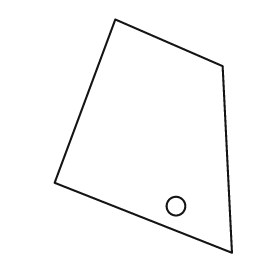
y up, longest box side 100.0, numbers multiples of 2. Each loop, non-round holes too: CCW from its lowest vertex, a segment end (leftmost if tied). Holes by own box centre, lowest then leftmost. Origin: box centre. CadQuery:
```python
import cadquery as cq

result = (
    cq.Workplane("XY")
    .moveTo(38.0, -50.0)
    .lineTo(34.0, 30.0)
    .lineTo(-12.0, 50.0)
    .lineTo(-38.0, -20.0)
    .close()
    .moveTo(14.0, -30.0)
    .circle(4.0)
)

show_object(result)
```